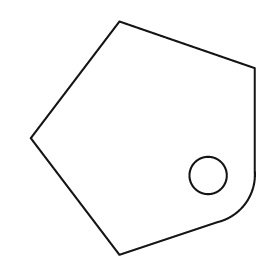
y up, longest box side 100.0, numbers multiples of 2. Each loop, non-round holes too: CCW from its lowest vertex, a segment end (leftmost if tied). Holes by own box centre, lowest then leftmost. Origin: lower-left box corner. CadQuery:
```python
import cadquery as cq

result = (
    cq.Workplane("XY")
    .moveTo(38.0, 0.0)
    .lineTo(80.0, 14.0)
    .threePointArc((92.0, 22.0), (96.0, 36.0))
    .lineTo(96.0, 80.0)
    .lineTo(38.0, 100.0)
    .lineTo(0.0, 50.0)
    .close()
    .moveTo(76.0, 34.0)
    .circle(8.0)
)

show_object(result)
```